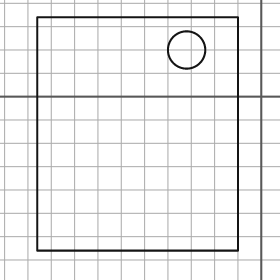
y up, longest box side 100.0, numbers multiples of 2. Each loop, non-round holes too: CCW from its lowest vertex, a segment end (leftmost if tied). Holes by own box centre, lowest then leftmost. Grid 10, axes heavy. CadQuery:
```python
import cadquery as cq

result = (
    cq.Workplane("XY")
    .moveTo(-96.0, -66.0)
    .lineTo(-10.0, -66.0)
    .lineTo(-10.0, 34.0)
    .lineTo(-96.0, 34.0)
    .close()
    .moveTo(-32.0, 20.0)
    .circle(8.0)
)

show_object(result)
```